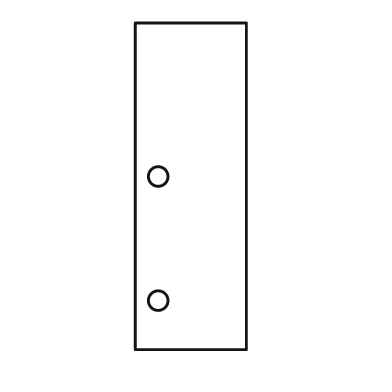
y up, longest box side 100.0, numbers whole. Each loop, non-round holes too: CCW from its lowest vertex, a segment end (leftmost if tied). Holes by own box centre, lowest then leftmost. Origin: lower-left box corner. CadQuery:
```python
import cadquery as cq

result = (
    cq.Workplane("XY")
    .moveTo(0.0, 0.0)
    .lineTo(34.0, 0.0)
    .lineTo(34.0, 100.0)
    .lineTo(0.0, 100.0)
    .close()
    .moveTo(7.0, 15.0)
    .circle(3.0)
    .moveTo(7.0, 53.0)
    .circle(3.0)
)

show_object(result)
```